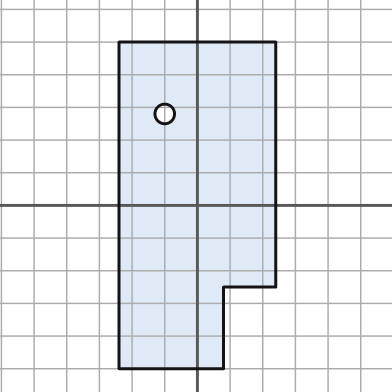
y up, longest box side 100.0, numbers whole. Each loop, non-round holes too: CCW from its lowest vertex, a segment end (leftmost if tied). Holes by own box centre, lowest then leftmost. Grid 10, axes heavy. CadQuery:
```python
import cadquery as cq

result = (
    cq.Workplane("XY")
    .moveTo(-24.0, -50.0)
    .lineTo(8.0, -50.0)
    .lineTo(8.0, -25.0)
    .lineTo(24.0, -25.0)
    .lineTo(24.0, 50.0)
    .lineTo(-24.0, 50.0)
    .close()
    .moveTo(-10.0, 28.0)
    .circle(3.0)
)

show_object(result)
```